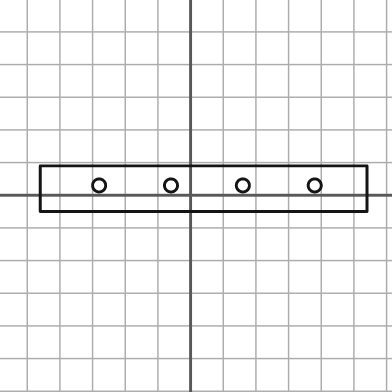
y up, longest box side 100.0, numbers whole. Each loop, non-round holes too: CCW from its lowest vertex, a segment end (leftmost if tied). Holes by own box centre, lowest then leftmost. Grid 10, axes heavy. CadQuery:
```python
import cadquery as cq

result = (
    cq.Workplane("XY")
    .moveTo(-46.0, -5.0)
    .lineTo(54.0, -5.0)
    .lineTo(54.0, 9.0)
    .lineTo(-46.0, 9.0)
    .close()
    .moveTo(-28.0, 3.0)
    .circle(2.0)
    .moveTo(-6.0, 3.0)
    .circle(2.0)
    .moveTo(16.0, 3.0)
    .circle(2.0)
    .moveTo(38.0, 3.0)
    .circle(2.0)
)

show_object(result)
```